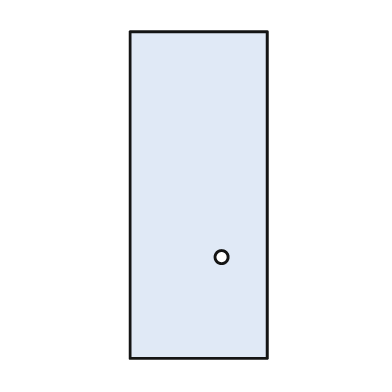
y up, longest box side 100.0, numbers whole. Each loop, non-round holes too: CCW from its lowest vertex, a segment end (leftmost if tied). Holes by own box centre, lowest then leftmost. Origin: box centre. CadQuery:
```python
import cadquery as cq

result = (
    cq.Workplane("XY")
    .moveTo(-21.0, -50.0)
    .lineTo(21.0, -50.0)
    .lineTo(21.0, 50.0)
    .lineTo(-21.0, 50.0)
    .close()
    .moveTo(7.0, -19.0)
    .circle(2.0)
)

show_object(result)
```